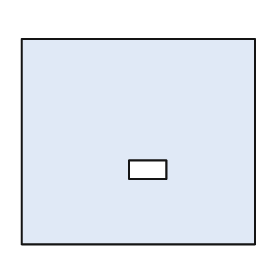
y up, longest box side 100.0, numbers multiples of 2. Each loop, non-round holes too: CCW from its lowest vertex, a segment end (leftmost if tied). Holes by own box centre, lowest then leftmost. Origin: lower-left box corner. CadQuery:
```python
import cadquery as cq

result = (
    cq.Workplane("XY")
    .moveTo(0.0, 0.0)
    .lineTo(100.0, 0.0)
    .lineTo(100.0, 88.0)
    .lineTo(0.0, 88.0)
    .close()
    .moveTo(46.0, 28.0)
    .lineTo(62.0, 28.0)
    .lineTo(62.0, 36.0)
    .lineTo(46.0, 36.0)
    .close()
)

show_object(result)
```